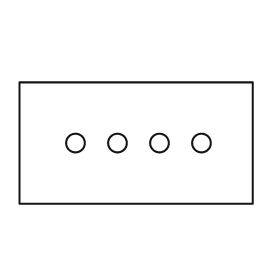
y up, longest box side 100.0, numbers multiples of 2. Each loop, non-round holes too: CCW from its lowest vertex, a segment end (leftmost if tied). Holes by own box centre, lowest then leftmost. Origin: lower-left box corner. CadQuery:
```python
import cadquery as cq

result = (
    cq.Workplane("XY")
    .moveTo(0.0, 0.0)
    .lineTo(100.0, 0.0)
    .lineTo(100.0, 52.0)
    .lineTo(0.0, 52.0)
    .close()
    .moveTo(24.0, 26.0)
    .circle(4.0)
    .moveTo(42.0, 26.0)
    .circle(4.0)
    .moveTo(60.0, 26.0)
    .circle(4.0)
    .moveTo(78.0, 26.0)
    .circle(4.0)
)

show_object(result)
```